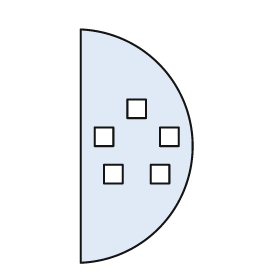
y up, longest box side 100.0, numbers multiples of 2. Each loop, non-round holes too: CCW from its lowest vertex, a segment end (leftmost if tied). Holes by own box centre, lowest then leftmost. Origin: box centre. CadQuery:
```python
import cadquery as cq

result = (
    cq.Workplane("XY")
    .moveTo(-24.0, -50.0)
    .threePointArc((24.0, 0.0), (-24.0, 50.0))
    .close()
    .moveTo(-14.0, -16.0)
    .lineTo(-6.0, -16.0)
    .lineTo(-6.0, -8.0)
    .lineTo(-14.0, -8.0)
    .close()
    .moveTo(6.0, -16.0)
    .lineTo(14.0, -16.0)
    .lineTo(14.0, -8.0)
    .lineTo(6.0, -8.0)
    .close()
    .moveTo(-18.0, 0.0)
    .lineTo(-10.0, 0.0)
    .lineTo(-10.0, 8.0)
    .lineTo(-18.0, 8.0)
    .close()
    .moveTo(10.0, 0.0)
    .lineTo(18.0, 0.0)
    .lineTo(18.0, 8.0)
    .lineTo(10.0, 8.0)
    .close()
    .moveTo(-4.0, 12.0)
    .lineTo(4.0, 12.0)
    .lineTo(4.0, 20.0)
    .lineTo(-4.0, 20.0)
    .close()
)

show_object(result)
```